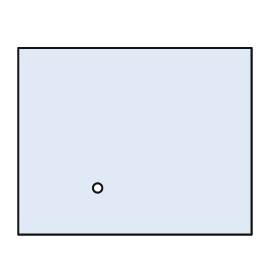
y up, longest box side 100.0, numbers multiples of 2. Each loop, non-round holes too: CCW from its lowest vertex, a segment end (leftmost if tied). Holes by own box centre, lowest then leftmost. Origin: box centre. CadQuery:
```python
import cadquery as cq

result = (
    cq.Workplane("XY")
    .moveTo(-50.0, -40.0)
    .lineTo(50.0, -40.0)
    .lineTo(50.0, 40.0)
    .lineTo(-50.0, 40.0)
    .close()
    .moveTo(-16.0, -20.0)
    .circle(2.0)
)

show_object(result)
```